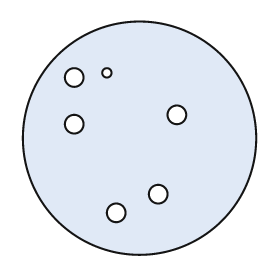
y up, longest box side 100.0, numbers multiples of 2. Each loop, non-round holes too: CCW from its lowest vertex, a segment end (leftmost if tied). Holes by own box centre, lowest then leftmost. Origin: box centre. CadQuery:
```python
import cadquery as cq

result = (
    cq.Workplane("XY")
    .moveTo(0.0, 0.0)
    .circle(50.0)
    .moveTo(-10.0, -32.0)
    .circle(4.0)
    .moveTo(8.0, -24.0)
    .circle(4.0)
    .moveTo(-28.0, 6.0)
    .circle(4.0)
    .moveTo(16.0, 10.0)
    .circle(4.0)
    .moveTo(-28.0, 26.0)
    .circle(4.0)
    .moveTo(-14.0, 28.0)
    .circle(2.0)
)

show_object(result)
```